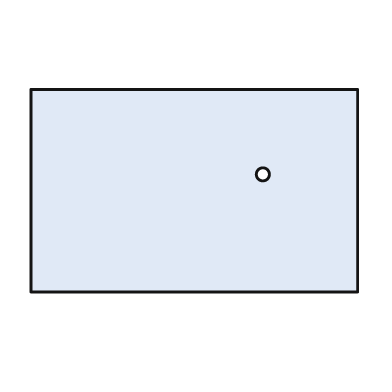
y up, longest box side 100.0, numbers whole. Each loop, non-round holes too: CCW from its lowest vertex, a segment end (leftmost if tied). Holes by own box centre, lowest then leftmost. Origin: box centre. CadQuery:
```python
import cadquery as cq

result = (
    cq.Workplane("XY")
    .moveTo(-50.0, -31.0)
    .lineTo(50.0, -31.0)
    .lineTo(50.0, 31.0)
    .lineTo(-50.0, 31.0)
    .close()
    .moveTo(21.0, 5.0)
    .circle(2.0)
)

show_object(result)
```